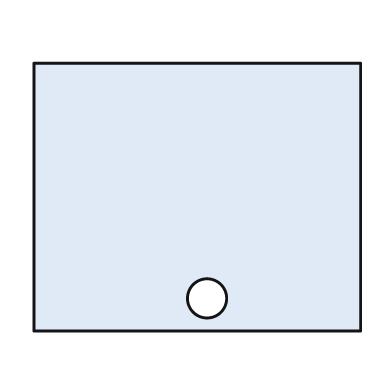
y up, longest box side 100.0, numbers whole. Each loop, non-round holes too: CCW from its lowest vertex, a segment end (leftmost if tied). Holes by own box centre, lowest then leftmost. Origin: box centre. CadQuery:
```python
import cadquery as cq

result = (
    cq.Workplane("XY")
    .moveTo(-50.0, -41.0)
    .lineTo(50.0, -41.0)
    .lineTo(50.0, 41.0)
    .lineTo(-50.0, 41.0)
    .close()
    .moveTo(3.0, -31.0)
    .circle(6.0)
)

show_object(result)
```